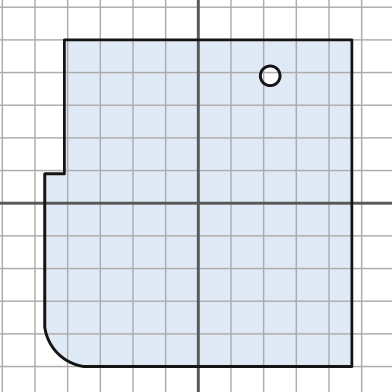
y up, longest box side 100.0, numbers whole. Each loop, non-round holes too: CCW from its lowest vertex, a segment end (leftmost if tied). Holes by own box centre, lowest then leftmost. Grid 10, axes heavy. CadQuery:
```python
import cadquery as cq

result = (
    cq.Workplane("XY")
    .moveTo(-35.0, -50.0)
    .lineTo(47.0, -50.0)
    .lineTo(47.0, 50.0)
    .lineTo(-41.0, 50.0)
    .lineTo(-41.0, 9.0)
    .lineTo(-47.0, 9.0)
    .lineTo(-47.0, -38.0)
    .threePointArc((-43.0, -46.0), (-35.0, -50.0))
    .close()
    .moveTo(22.0, 39.0)
    .circle(3.0)
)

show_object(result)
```